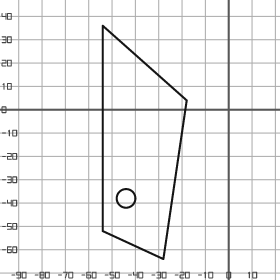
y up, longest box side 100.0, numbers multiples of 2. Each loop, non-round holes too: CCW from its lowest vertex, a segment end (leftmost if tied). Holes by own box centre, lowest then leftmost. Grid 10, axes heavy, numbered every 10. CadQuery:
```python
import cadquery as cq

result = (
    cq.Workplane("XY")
    .moveTo(-28.0, -64.0)
    .lineTo(-18.0, 4.0)
    .lineTo(-54.0, 36.0)
    .lineTo(-54.0, -52.0)
    .close()
    .moveTo(-44.0, -38.0)
    .circle(4.0)
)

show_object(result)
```